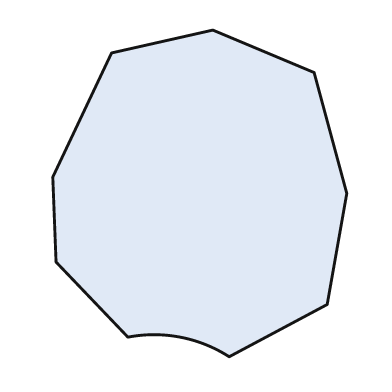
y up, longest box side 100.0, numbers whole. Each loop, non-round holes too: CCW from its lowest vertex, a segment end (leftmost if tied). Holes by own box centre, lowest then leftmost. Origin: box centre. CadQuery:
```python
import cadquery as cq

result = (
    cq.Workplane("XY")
    .moveTo(9.0, -50.0)
    .lineTo(39.0, -34.0)
    .lineTo(45.0, 0.0)
    .lineTo(35.0, 37.0)
    .lineTo(4.0, 50.0)
    .lineTo(-27.0, 43.0)
    .lineTo(-45.0, 5.0)
    .lineTo(-44.0, -21.0)
    .lineTo(-22.0, -44.0)
    .threePointArc((-6.0, -44.0), (9.0, -50.0))
    .close()
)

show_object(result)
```